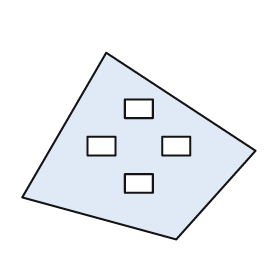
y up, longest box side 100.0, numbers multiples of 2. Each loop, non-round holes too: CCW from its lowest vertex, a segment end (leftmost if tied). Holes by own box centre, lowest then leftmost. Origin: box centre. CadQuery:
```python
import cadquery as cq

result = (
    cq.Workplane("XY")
    .moveTo(16.0, -40.0)
    .lineTo(50.0, -2.0)
    .lineTo(-14.0, 40.0)
    .lineTo(-50.0, -22.0)
    .close()
    .moveTo(-6.0, -20.0)
    .lineTo(6.0, -20.0)
    .lineTo(6.0, -12.0)
    .lineTo(-6.0, -12.0)
    .close()
    .moveTo(-22.0, -4.0)
    .lineTo(-10.0, -4.0)
    .lineTo(-10.0, 4.0)
    .lineTo(-22.0, 4.0)
    .close()
    .moveTo(10.0, -4.0)
    .lineTo(22.0, -4.0)
    .lineTo(22.0, 4.0)
    .lineTo(10.0, 4.0)
    .close()
    .moveTo(-6.0, 12.0)
    .lineTo(6.0, 12.0)
    .lineTo(6.0, 20.0)
    .lineTo(-6.0, 20.0)
    .close()
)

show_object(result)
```